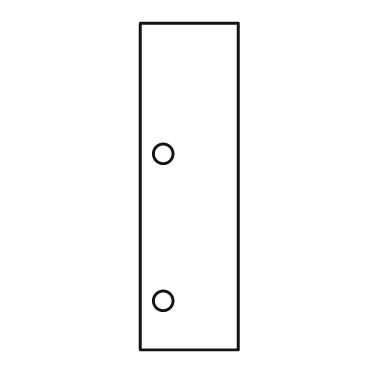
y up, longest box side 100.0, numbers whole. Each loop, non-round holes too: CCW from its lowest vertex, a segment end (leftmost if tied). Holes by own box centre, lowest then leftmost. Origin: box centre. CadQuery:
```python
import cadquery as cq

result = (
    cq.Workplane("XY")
    .moveTo(-15.0, -50.0)
    .lineTo(15.0, -50.0)
    .lineTo(15.0, 50.0)
    .lineTo(-15.0, 50.0)
    .close()
    .moveTo(-8.0, -35.0)
    .circle(3.0)
    .moveTo(-8.0, 10.0)
    .circle(3.0)
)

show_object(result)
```